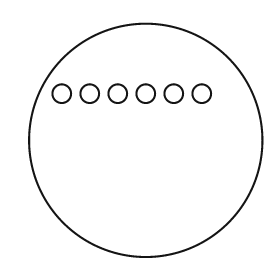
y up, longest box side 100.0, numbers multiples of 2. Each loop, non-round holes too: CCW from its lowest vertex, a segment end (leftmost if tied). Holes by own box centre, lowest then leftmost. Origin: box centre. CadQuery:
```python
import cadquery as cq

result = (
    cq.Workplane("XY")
    .moveTo(0.0, 0.0)
    .circle(50.0)
    .moveTo(-36.0, 20.0)
    .circle(4.0)
    .moveTo(-24.0, 20.0)
    .circle(4.0)
    .moveTo(-12.0, 20.0)
    .circle(4.0)
    .moveTo(0.0, 20.0)
    .circle(4.0)
    .moveTo(12.0, 20.0)
    .circle(4.0)
    .moveTo(24.0, 20.0)
    .circle(4.0)
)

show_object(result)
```